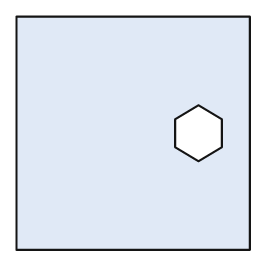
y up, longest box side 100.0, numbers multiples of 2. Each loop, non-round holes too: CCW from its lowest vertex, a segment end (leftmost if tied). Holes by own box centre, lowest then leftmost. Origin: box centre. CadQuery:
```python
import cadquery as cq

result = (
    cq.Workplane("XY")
    .moveTo(-50.0, -50.0)
    .lineTo(50.0, -50.0)
    .lineTo(50.0, 50.0)
    .lineTo(-50.0, 50.0)
    .close()
    .moveTo(28.0, -12.0)
    .lineTo(38.0, -6.0)
    .lineTo(38.0, 6.0)
    .lineTo(28.0, 12.0)
    .lineTo(18.0, 6.0)
    .lineTo(18.0, -6.0)
    .close()
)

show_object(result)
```